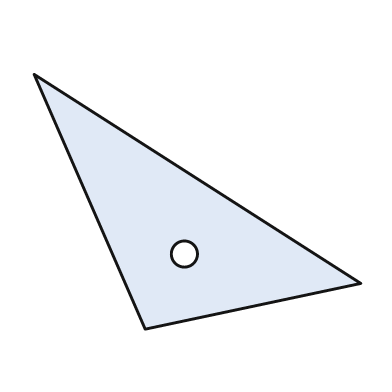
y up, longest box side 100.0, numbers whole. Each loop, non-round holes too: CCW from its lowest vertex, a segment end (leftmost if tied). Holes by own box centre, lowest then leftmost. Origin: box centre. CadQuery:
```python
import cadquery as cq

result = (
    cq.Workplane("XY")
    .moveTo(-16.0, -39.0)
    .lineTo(50.0, -25.0)
    .lineTo(-50.0, 39.0)
    .close()
    .moveTo(-4.0, -16.0)
    .circle(4.0)
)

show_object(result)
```